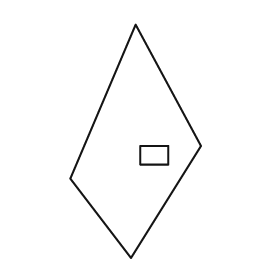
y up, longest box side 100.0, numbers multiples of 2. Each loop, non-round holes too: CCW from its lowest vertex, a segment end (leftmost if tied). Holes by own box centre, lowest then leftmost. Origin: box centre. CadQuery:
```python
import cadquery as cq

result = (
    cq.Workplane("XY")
    .moveTo(-2.0, -50.0)
    .lineTo(28.0, -2.0)
    .lineTo(0.0, 50.0)
    .lineTo(-28.0, -16.0)
    .close()
    .moveTo(2.0, -10.0)
    .lineTo(14.0, -10.0)
    .lineTo(14.0, -2.0)
    .lineTo(2.0, -2.0)
    .close()
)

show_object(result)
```